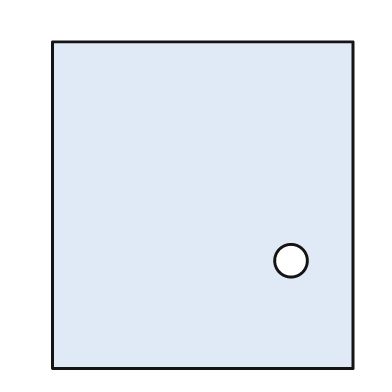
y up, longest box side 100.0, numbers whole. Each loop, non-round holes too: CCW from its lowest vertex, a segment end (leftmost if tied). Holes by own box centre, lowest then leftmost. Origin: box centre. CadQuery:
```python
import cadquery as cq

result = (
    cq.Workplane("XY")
    .moveTo(-46.0, -50.0)
    .lineTo(46.0, -50.0)
    .lineTo(46.0, 50.0)
    .lineTo(-46.0, 50.0)
    .close()
    .moveTo(27.0, -17.0)
    .circle(5.0)
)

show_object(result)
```